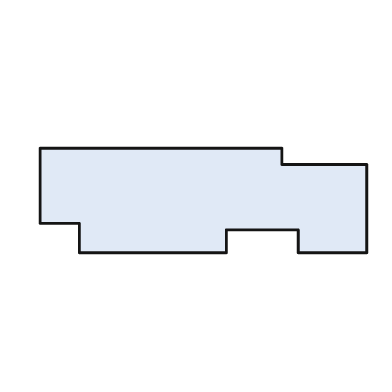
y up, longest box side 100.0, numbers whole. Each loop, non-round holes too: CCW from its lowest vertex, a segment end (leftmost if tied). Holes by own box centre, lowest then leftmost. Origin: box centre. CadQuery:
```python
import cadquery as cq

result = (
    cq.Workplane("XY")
    .moveTo(-38.0, -16.0)
    .lineTo(7.0, -16.0)
    .lineTo(7.0, -9.0)
    .lineTo(29.0, -9.0)
    .lineTo(29.0, -16.0)
    .lineTo(50.0, -16.0)
    .lineTo(50.0, 11.0)
    .lineTo(24.0, 11.0)
    .lineTo(24.0, 16.0)
    .lineTo(-50.0, 16.0)
    .lineTo(-50.0, -7.0)
    .lineTo(-38.0, -7.0)
    .close()
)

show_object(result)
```